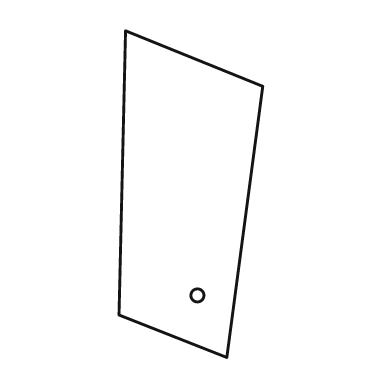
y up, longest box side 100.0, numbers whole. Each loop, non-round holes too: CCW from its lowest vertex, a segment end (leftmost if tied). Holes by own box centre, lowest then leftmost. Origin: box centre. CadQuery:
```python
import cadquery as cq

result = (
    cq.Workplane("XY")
    .moveTo(11.0, -50.0)
    .lineTo(22.0, 33.0)
    .lineTo(-20.0, 50.0)
    .lineTo(-22.0, -37.0)
    .close()
    .moveTo(2.0, -31.0)
    .circle(2.0)
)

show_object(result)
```